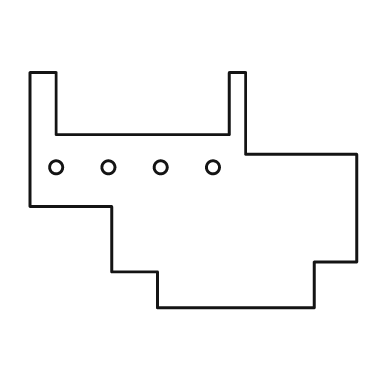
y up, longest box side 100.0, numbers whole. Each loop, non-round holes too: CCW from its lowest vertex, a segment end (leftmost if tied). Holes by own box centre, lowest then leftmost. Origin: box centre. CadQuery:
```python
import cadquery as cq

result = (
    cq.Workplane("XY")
    .moveTo(-11.0, -36.0)
    .lineTo(37.0, -36.0)
    .lineTo(37.0, -22.0)
    .lineTo(50.0, -22.0)
    .lineTo(50.0, 11.0)
    .lineTo(16.0, 11.0)
    .lineTo(16.0, 36.0)
    .lineTo(11.0, 36.0)
    .lineTo(11.0, 17.0)
    .lineTo(-42.0, 17.0)
    .lineTo(-42.0, 36.0)
    .lineTo(-50.0, 36.0)
    .lineTo(-50.0, -5.0)
    .lineTo(-25.0, -5.0)
    .lineTo(-25.0, -25.0)
    .lineTo(-11.0, -25.0)
    .close()
    .moveTo(-42.0, 7.0)
    .circle(2.0)
    .moveTo(-26.0, 7.0)
    .circle(2.0)
    .moveTo(-10.0, 7.0)
    .circle(2.0)
    .moveTo(6.0, 7.0)
    .circle(2.0)
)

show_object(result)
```